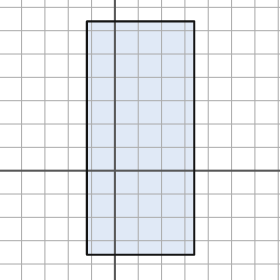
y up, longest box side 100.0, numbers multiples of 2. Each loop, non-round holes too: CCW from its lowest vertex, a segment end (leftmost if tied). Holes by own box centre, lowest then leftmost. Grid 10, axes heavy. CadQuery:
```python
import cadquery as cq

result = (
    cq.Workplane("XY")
    .moveTo(-12.0, -36.0)
    .lineTo(34.0, -36.0)
    .lineTo(34.0, 64.0)
    .lineTo(-12.0, 64.0)
    .close()
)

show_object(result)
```